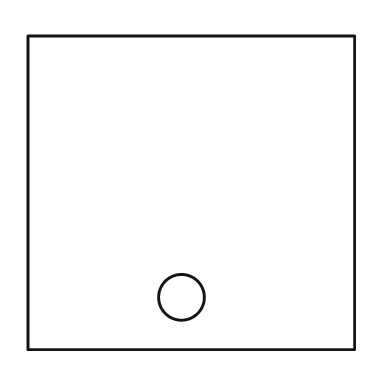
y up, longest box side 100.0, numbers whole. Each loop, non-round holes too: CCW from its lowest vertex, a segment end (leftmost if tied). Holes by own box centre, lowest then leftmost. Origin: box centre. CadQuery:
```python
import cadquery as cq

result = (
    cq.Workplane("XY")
    .moveTo(-50.0, -48.0)
    .lineTo(50.0, -48.0)
    .lineTo(50.0, 48.0)
    .lineTo(-50.0, 48.0)
    .close()
    .moveTo(-3.0, -32.0)
    .circle(7.0)
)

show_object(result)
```